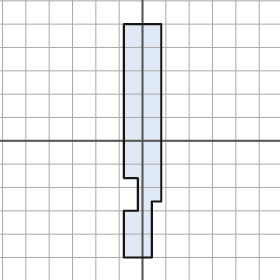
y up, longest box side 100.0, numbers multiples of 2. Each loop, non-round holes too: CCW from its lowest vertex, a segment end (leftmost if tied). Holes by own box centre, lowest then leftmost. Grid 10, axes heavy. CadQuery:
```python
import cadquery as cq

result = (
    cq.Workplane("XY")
    .moveTo(-8.0, -50.0)
    .lineTo(4.0, -50.0)
    .lineTo(4.0, -26.0)
    .lineTo(8.0, -26.0)
    .lineTo(8.0, 50.0)
    .lineTo(-8.0, 50.0)
    .lineTo(-8.0, -16.0)
    .lineTo(-2.0, -16.0)
    .lineTo(-2.0, -30.0)
    .lineTo(-8.0, -30.0)
    .close()
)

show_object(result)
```